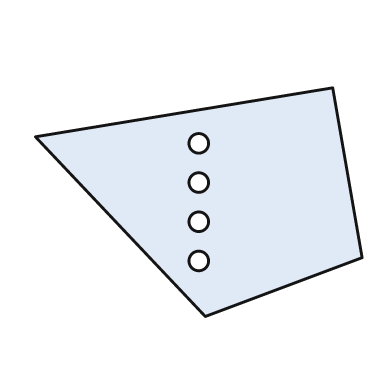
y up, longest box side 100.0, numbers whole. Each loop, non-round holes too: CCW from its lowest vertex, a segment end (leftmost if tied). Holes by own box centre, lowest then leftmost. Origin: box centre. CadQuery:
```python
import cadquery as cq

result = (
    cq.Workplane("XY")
    .moveTo(2.0, -35.0)
    .lineTo(50.0, -17.0)
    .lineTo(41.0, 35.0)
    .lineTo(-50.0, 20.0)
    .close()
    .moveTo(0.0, -18.0)
    .circle(3.0)
    .moveTo(0.0, -6.0)
    .circle(3.0)
    .moveTo(0.0, 6.0)
    .circle(3.0)
    .moveTo(0.0, 18.0)
    .circle(3.0)
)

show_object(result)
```